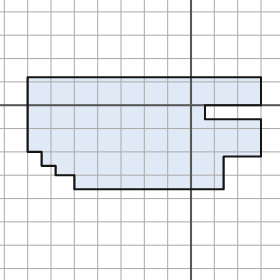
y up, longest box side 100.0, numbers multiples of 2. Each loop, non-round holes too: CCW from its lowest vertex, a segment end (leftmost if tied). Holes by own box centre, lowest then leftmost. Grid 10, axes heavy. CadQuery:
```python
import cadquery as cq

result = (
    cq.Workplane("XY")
    .moveTo(-50.0, -36.0)
    .lineTo(14.0, -36.0)
    .lineTo(14.0, -22.0)
    .lineTo(30.0, -22.0)
    .lineTo(30.0, -6.0)
    .lineTo(6.0, -6.0)
    .lineTo(6.0, 0.0)
    .lineTo(30.0, 0.0)
    .lineTo(30.0, 12.0)
    .lineTo(-70.0, 12.0)
    .lineTo(-70.0, -20.0)
    .lineTo(-64.0, -20.0)
    .lineTo(-64.0, -26.0)
    .lineTo(-58.0, -26.0)
    .lineTo(-58.0, -30.0)
    .lineTo(-50.0, -30.0)
    .close()
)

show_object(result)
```